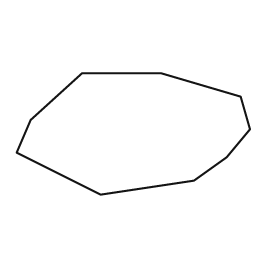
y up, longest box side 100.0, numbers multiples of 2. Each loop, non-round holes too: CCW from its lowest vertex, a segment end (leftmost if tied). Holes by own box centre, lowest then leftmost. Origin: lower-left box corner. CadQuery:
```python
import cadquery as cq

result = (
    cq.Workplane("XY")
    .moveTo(36.0, 0.0)
    .lineTo(76.0, 6.0)
    .lineTo(90.0, 16.0)
    .lineTo(100.0, 28.0)
    .lineTo(96.0, 42.0)
    .lineTo(62.0, 52.0)
    .lineTo(28.0, 52.0)
    .lineTo(6.0, 32.0)
    .lineTo(0.0, 18.0)
    .close()
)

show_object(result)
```